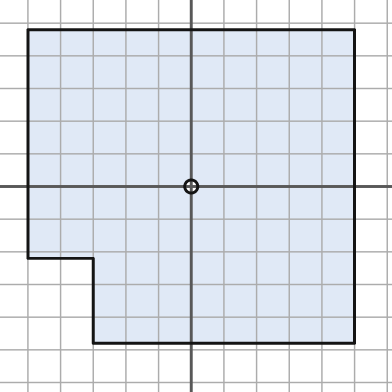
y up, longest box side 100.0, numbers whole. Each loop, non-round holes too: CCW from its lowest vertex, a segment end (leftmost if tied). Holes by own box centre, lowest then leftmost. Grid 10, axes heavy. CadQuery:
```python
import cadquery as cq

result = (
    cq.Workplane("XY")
    .moveTo(-30.0, -48.0)
    .lineTo(50.0, -48.0)
    .lineTo(50.0, 48.0)
    .lineTo(-50.0, 48.0)
    .lineTo(-50.0, -22.0)
    .lineTo(-30.0, -22.0)
    .close()
    .moveTo(0.0, 0.0)
    .circle(2.0)
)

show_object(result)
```